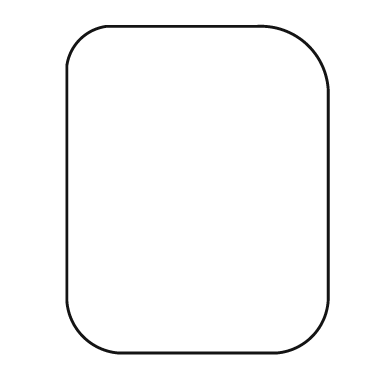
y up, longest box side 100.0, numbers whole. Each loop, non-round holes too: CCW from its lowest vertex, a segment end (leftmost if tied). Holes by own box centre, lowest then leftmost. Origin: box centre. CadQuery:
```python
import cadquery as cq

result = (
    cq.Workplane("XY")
    .moveTo(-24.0, -50.0)
    .lineTo(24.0, -50.0)
    .threePointArc((35.0, -45.0), (40.0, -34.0))
    .lineTo(40.0, 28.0)
    .threePointArc((34.0, 44.0), (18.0, 50.0))
    .lineTo(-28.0, 50.0)
    .threePointArc((-36.0, 46.0), (-40.0, 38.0))
    .lineTo(-40.0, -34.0)
    .threePointArc((-35.0, -45.0), (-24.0, -50.0))
    .close()
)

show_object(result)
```